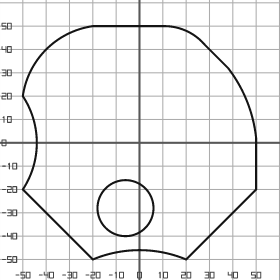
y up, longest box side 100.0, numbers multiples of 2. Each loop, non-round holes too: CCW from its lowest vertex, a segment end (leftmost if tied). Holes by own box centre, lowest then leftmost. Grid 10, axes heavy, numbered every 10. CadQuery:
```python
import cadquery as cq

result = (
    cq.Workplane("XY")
    .moveTo(-20.0, -50.0)
    .threePointArc((0.0, -46.0), (20.0, -50.0))
    .lineTo(50.0, -20.0)
    .lineTo(50.0, 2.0)
    .threePointArc((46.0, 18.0), (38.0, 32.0))
    .lineTo(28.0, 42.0)
    .threePointArc((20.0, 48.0), (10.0, 50.0))
    .lineTo(-20.0, 50.0)
    .threePointArc((-40.0, 40.0), (-50.0, 20.0))
    .threePointArc((-44.0, 0.0), (-50.0, -20.0))
    .close()
    .moveTo(-6.0, -28.0)
    .circle(12.0)
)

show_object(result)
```